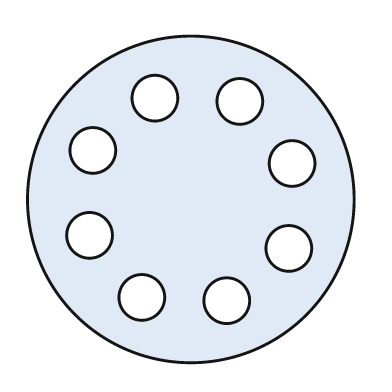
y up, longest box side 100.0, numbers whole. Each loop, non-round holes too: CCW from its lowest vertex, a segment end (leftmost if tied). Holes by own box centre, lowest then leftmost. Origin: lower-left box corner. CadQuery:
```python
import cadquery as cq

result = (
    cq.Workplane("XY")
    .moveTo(50.0, 50.0)
    .circle(50.0)
    .moveTo(61.0, 19.0)
    .circle(7.0)
    .moveTo(35.0, 20.0)
    .circle(7.0)
    .moveTo(80.0, 35.0)
    .circle(7.0)
    .moveTo(19.0, 39.0)
    .circle(7.0)
    .moveTo(81.0, 61.0)
    .circle(7.0)
    .moveTo(20.0, 65.0)
    .circle(7.0)
    .moveTo(65.0, 80.0)
    .circle(7.0)
    .moveTo(39.0, 81.0)
    .circle(7.0)
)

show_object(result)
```